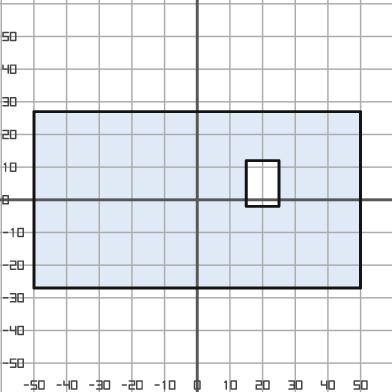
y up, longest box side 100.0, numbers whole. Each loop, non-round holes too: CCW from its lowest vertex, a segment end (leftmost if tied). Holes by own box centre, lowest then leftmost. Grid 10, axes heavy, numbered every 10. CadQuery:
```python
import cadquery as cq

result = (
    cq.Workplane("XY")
    .moveTo(-50.0, -27.0)
    .lineTo(50.0, -27.0)
    .lineTo(50.0, 27.0)
    .lineTo(-50.0, 27.0)
    .close()
    .moveTo(15.0, -2.0)
    .lineTo(25.0, -2.0)
    .lineTo(25.0, 12.0)
    .lineTo(15.0, 12.0)
    .close()
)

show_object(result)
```